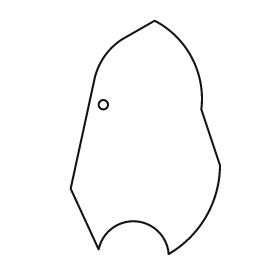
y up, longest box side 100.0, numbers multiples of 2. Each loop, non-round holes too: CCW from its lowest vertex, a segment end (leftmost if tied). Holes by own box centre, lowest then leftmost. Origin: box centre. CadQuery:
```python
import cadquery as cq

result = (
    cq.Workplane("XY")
    .moveTo(10.0, -50.0)
    .threePointArc((26.0, -34.0), (32.0, -12.0))
    .lineTo(24.0, 12.0)
    .threePointArc((20.0, 34.0), (4.0, 50.0))
    .lineTo(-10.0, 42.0)
    .threePointArc((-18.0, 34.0), (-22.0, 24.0))
    .lineTo(-32.0, -22.0)
    .lineTo(-20.0, -48.0)
    .threePointArc((-4.0, -36.0), (10.0, -50.0))
    .close()
    .moveTo(-18.0, 14.0)
    .circle(2.0)
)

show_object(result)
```